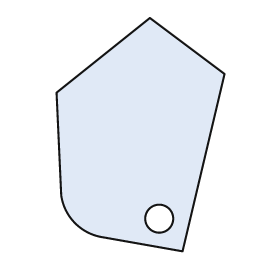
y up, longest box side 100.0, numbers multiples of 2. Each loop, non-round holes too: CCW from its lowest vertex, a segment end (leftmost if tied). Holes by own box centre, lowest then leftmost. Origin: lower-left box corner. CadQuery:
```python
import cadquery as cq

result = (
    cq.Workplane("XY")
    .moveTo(54.0, 0.0)
    .lineTo(72.0, 76.0)
    .lineTo(40.0, 100.0)
    .lineTo(0.0, 68.0)
    .lineTo(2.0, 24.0)
    .threePointArc((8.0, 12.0), (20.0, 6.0))
    .close()
    .moveTo(44.0, 14.0)
    .circle(6.0)
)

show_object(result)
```